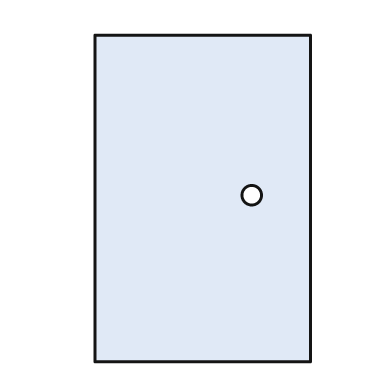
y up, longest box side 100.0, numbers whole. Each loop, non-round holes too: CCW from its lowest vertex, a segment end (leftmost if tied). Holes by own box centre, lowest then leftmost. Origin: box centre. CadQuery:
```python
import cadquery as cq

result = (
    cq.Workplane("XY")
    .moveTo(-33.0, -50.0)
    .lineTo(33.0, -50.0)
    .lineTo(33.0, 50.0)
    .lineTo(-33.0, 50.0)
    .close()
    .moveTo(15.0, 1.0)
    .circle(3.0)
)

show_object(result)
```